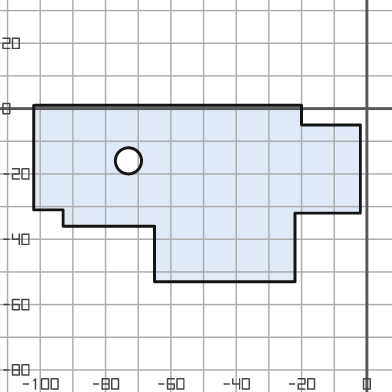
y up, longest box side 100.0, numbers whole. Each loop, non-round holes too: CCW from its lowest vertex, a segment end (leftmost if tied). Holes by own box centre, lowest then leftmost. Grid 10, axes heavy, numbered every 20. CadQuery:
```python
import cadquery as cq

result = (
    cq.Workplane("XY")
    .moveTo(-65.0, -53.0)
    .lineTo(-22.0, -53.0)
    .lineTo(-22.0, -32.0)
    .lineTo(-2.0, -32.0)
    .lineTo(-2.0, -5.0)
    .lineTo(-20.0, -5.0)
    .lineTo(-20.0, 1.0)
    .lineTo(-102.0, 1.0)
    .lineTo(-102.0, -31.0)
    .lineTo(-93.0, -31.0)
    .lineTo(-93.0, -36.0)
    .lineTo(-65.0, -36.0)
    .close()
    .moveTo(-73.0, -16.0)
    .circle(4.0)
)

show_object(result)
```